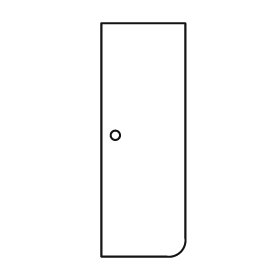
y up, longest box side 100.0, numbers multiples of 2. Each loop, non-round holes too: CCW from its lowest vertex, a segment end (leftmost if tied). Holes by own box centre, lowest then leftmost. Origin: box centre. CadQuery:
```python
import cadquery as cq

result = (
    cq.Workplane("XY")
    .moveTo(-18.0, -50.0)
    .lineTo(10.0, -50.0)
    .threePointArc((16.0, -48.0), (18.0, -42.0))
    .lineTo(18.0, 50.0)
    .lineTo(-18.0, 50.0)
    .close()
    .moveTo(-12.0, 2.0)
    .circle(2.0)
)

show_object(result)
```